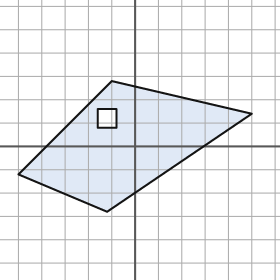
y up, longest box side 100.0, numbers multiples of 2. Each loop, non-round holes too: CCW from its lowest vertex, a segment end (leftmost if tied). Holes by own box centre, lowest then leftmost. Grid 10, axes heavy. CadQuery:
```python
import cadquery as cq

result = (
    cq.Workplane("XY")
    .moveTo(-12.0, -28.0)
    .lineTo(50.0, 14.0)
    .lineTo(-10.0, 28.0)
    .lineTo(-50.0, -12.0)
    .close()
    .moveTo(-16.0, 8.0)
    .lineTo(-8.0, 8.0)
    .lineTo(-8.0, 16.0)
    .lineTo(-16.0, 16.0)
    .close()
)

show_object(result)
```